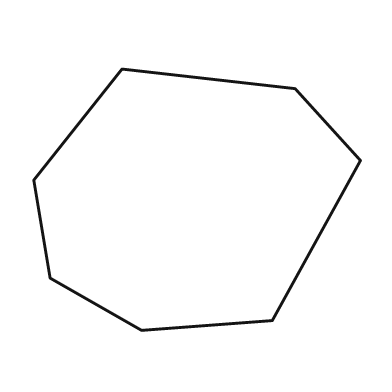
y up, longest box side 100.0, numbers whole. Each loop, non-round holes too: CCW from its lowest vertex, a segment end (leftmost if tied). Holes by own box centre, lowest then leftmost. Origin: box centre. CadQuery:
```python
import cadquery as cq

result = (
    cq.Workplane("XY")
    .moveTo(-17.0, -40.0)
    .lineTo(23.0, -37.0)
    .lineTo(50.0, 12.0)
    .lineTo(30.0, 34.0)
    .lineTo(-23.0, 40.0)
    .lineTo(-50.0, 6.0)
    .lineTo(-45.0, -24.0)
    .close()
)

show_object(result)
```